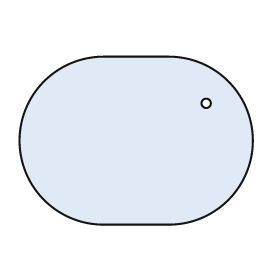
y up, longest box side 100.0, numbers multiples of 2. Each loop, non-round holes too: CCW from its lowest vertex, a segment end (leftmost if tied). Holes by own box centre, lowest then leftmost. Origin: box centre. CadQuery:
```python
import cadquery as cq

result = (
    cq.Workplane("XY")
    .moveTo(-14.0, -36.0)
    .lineTo(14.0, -36.0)
    .threePointArc((50.0, 0.0), (14.0, 36.0))
    .lineTo(-14.0, 36.0)
    .threePointArc((-50.0, 0.0), (-14.0, -36.0))
    .close()
    .moveTo(30.0, 16.0)
    .circle(2.0)
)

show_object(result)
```